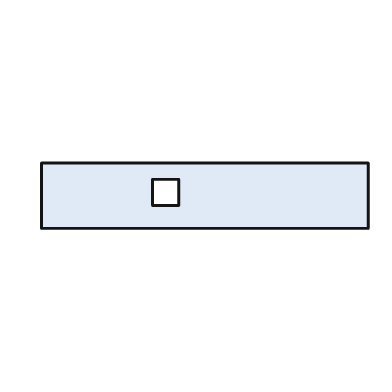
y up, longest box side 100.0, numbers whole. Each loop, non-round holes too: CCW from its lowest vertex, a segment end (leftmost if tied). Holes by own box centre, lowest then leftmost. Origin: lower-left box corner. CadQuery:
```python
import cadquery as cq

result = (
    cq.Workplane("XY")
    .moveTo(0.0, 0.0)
    .lineTo(100.0, 0.0)
    .lineTo(100.0, 20.0)
    .lineTo(0.0, 20.0)
    .close()
    .moveTo(34.0, 7.0)
    .lineTo(42.0, 7.0)
    .lineTo(42.0, 15.0)
    .lineTo(34.0, 15.0)
    .close()
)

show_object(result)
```